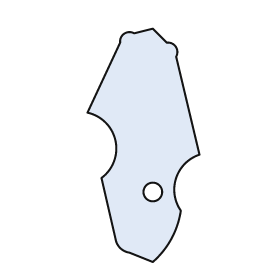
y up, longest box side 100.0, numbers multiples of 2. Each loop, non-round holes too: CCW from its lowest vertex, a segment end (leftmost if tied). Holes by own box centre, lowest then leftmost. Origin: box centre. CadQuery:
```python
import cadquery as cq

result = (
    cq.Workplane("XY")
    .moveTo(4.0, -50.0)
    .threePointArc((12.0, -40.0), (16.0, -28.0))
    .threePointArc((14.0, -14.0), (24.0, -4.0))
    .lineTo(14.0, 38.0)
    .threePointArc((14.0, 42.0), (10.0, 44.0))
    .lineTo(4.0, 50.0)
    .lineTo(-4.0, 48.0)
    .threePointArc((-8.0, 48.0), (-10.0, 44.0))
    .lineTo(-24.0, 14.0)
    .threePointArc((-12.0, 2.0), (-18.0, -14.0))
    .lineTo(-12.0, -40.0)
    .threePointArc((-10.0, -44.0), (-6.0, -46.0))
    .close()
    .moveTo(4.0, -20.0)
    .circle(4.0)
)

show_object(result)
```